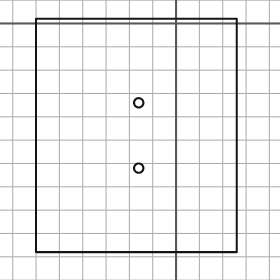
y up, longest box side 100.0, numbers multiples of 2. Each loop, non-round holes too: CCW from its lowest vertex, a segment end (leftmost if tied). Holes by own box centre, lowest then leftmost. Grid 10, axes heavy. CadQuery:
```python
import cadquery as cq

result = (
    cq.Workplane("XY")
    .moveTo(-60.0, -98.0)
    .lineTo(26.0, -98.0)
    .lineTo(26.0, 2.0)
    .lineTo(-60.0, 2.0)
    .close()
    .moveTo(-16.0, -62.0)
    .circle(2.0)
    .moveTo(-16.0, -34.0)
    .circle(2.0)
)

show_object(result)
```